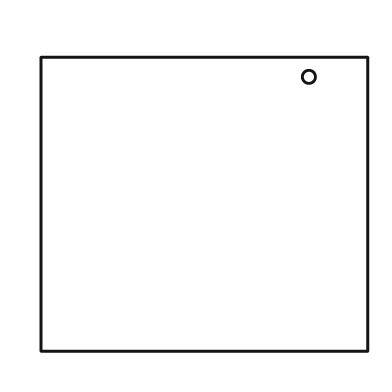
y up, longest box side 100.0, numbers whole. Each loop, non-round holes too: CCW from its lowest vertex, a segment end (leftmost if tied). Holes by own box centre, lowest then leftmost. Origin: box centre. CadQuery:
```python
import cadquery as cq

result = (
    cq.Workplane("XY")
    .moveTo(-50.0, -45.0)
    .lineTo(50.0, -45.0)
    .lineTo(50.0, 45.0)
    .lineTo(-50.0, 45.0)
    .close()
    .moveTo(32.0, 39.0)
    .circle(2.0)
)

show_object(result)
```